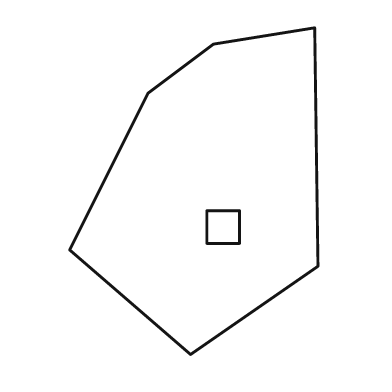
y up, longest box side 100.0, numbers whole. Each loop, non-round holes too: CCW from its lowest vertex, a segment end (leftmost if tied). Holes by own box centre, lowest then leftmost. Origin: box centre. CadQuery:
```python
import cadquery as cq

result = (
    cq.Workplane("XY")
    .moveTo(-1.0, -50.0)
    .lineTo(38.0, -23.0)
    .lineTo(37.0, 50.0)
    .lineTo(6.0, 45.0)
    .lineTo(-14.0, 30.0)
    .lineTo(-38.0, -18.0)
    .close()
    .moveTo(4.0, -16.0)
    .lineTo(14.0, -16.0)
    .lineTo(14.0, -6.0)
    .lineTo(4.0, -6.0)
    .close()
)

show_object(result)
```